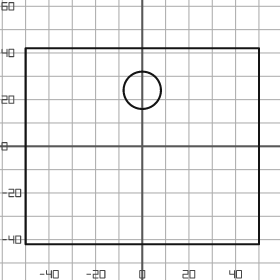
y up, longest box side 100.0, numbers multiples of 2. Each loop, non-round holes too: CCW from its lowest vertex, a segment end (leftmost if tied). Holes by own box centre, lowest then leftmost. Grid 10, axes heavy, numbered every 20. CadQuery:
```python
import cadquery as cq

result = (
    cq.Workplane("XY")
    .moveTo(-50.0, -42.0)
    .lineTo(50.0, -42.0)
    .lineTo(50.0, 42.0)
    .lineTo(-50.0, 42.0)
    .close()
    .moveTo(0.0, 24.0)
    .circle(8.0)
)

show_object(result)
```